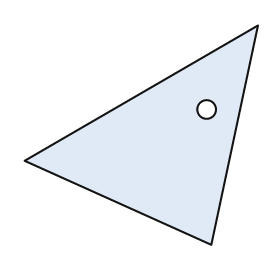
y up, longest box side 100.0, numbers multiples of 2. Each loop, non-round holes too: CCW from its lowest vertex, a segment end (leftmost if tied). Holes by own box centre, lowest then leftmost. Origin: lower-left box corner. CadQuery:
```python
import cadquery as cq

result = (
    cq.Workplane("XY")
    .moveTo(80.0, 0.0)
    .lineTo(100.0, 94.0)
    .lineTo(0.0, 36.0)
    .close()
    .moveTo(78.0, 58.0)
    .circle(4.0)
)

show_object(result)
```